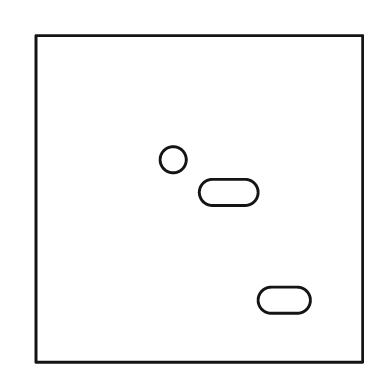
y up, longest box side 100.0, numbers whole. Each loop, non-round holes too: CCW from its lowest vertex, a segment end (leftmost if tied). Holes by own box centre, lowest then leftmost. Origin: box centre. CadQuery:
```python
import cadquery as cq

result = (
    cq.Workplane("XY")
    .moveTo(-50.0, -50.0)
    .lineTo(50.0, -50.0)
    .lineTo(50.0, 50.0)
    .lineTo(-50.0, 50.0)
    .close()
    .moveTo(22.0, -35.0)
    .lineTo(30.0, -35.0)
    .threePointArc((34.0, -31.0), (30.0, -27.0))
    .lineTo(22.0, -27.0)
    .threePointArc((18.0, -31.0), (22.0, -35.0))
    .close()
    .moveTo(4.0, -2.0)
    .lineTo(14.0, -2.0)
    .threePointArc((18.0, 2.0), (14.0, 6.0))
    .lineTo(4.0, 6.0)
    .threePointArc((0.0, 2.0), (4.0, -2.0))
    .close()
    .moveTo(-8.0, 12.0)
    .circle(4.0)
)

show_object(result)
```